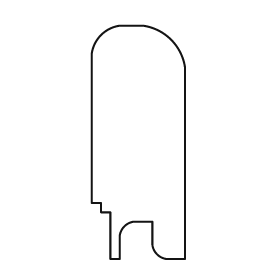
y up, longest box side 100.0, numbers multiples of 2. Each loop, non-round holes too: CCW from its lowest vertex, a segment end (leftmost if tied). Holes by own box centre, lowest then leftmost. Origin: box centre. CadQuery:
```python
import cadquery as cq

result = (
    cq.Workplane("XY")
    .moveTo(-12.0, -50.0)
    .lineTo(-8.0, -50.0)
    .lineTo(-8.0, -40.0)
    .threePointArc((-6.0, -36.0), (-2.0, -34.0))
    .lineTo(6.0, -34.0)
    .lineTo(6.0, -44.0)
    .threePointArc((8.0, -48.0), (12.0, -50.0))
    .lineTo(20.0, -50.0)
    .lineTo(20.0, 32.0)
    .threePointArc((14.0, 44.0), (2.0, 50.0))
    .lineTo(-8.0, 50.0)
    .threePointArc((-16.0, 46.0), (-20.0, 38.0))
    .lineTo(-20.0, -26.0)
    .lineTo(-16.0, -26.0)
    .lineTo(-16.0, -30.0)
    .lineTo(-12.0, -30.0)
    .close()
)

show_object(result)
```